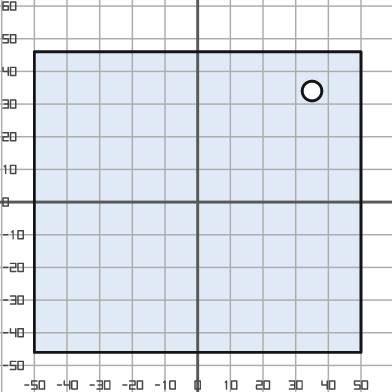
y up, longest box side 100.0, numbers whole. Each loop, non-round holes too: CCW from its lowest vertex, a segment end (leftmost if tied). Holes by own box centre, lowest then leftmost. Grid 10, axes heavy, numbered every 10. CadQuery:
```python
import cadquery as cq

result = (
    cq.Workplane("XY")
    .moveTo(-50.0, -46.0)
    .lineTo(50.0, -46.0)
    .lineTo(50.0, 46.0)
    .lineTo(-50.0, 46.0)
    .close()
    .moveTo(35.0, 34.0)
    .circle(3.0)
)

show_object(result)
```